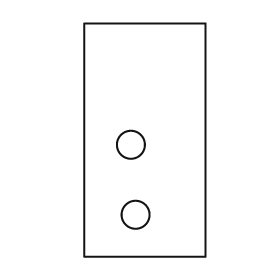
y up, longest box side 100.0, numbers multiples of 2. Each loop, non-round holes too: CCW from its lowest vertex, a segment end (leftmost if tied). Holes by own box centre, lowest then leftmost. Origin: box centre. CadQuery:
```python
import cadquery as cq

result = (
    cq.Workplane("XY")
    .moveTo(-26.0, -50.0)
    .lineTo(26.0, -50.0)
    .lineTo(26.0, 50.0)
    .lineTo(-26.0, 50.0)
    .close()
    .moveTo(-4.0, -32.0)
    .circle(6.0)
    .moveTo(-6.0, -2.0)
    .circle(6.0)
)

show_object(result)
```